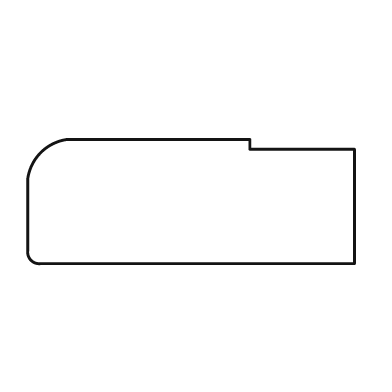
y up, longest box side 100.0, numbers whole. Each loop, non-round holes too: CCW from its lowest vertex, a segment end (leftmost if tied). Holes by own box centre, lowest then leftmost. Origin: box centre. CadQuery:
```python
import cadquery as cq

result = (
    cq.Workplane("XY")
    .moveTo(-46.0, -19.0)
    .lineTo(50.0, -19.0)
    .lineTo(50.0, 16.0)
    .lineTo(18.0, 16.0)
    .lineTo(18.0, 19.0)
    .lineTo(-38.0, 19.0)
    .threePointArc((-46.0, 15.0), (-50.0, 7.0))
    .lineTo(-50.0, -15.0)
    .threePointArc((-49.0, -18.0), (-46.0, -19.0))
    .close()
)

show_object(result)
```